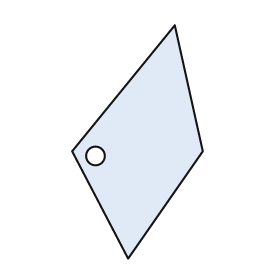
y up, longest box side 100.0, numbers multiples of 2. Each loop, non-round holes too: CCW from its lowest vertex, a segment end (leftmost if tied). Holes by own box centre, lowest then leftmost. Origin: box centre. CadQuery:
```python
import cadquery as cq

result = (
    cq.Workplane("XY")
    .moveTo(-4.0, -50.0)
    .lineTo(28.0, -4.0)
    .lineTo(16.0, 50.0)
    .lineTo(-28.0, -4.0)
    .close()
    .moveTo(-18.0, -6.0)
    .circle(4.0)
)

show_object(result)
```